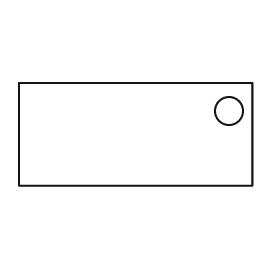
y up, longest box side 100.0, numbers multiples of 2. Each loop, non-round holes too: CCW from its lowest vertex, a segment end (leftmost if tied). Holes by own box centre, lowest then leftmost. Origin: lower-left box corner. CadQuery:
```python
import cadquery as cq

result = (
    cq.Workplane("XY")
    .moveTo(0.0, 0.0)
    .lineTo(100.0, 0.0)
    .lineTo(100.0, 44.0)
    .lineTo(0.0, 44.0)
    .close()
    .moveTo(90.0, 32.0)
    .circle(6.0)
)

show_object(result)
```